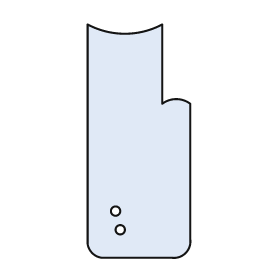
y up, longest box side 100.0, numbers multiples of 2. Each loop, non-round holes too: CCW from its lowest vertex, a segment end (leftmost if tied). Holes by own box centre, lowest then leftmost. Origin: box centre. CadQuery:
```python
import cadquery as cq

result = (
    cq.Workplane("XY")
    .moveTo(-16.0, -50.0)
    .lineTo(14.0, -50.0)
    .threePointArc((20.0, -48.0), (22.0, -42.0))
    .lineTo(22.0, 16.0)
    .threePointArc((16.0, 18.0), (10.0, 16.0))
    .lineTo(10.0, 50.0)
    .threePointArc((-6.0, 46.0), (-22.0, 50.0))
    .lineTo(-22.0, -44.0)
    .threePointArc((-20.0, -48.0), (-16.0, -50.0))
    .close()
    .moveTo(-8.0, -38.0)
    .circle(2.0)
    .moveTo(-10.0, -30.0)
    .circle(2.0)
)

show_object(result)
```